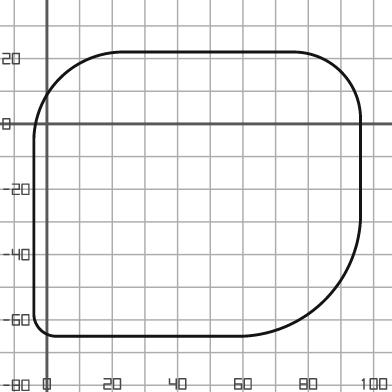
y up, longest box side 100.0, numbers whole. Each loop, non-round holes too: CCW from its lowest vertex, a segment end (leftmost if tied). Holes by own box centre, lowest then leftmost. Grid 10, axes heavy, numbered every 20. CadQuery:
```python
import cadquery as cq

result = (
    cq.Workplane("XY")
    .moveTo(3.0, -65.0)
    .lineTo(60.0, -65.0)
    .threePointArc((85.0, -54.0), (96.0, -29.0))
    .lineTo(96.0, 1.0)
    .threePointArc((90.0, 16.0), (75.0, 22.0))
    .lineTo(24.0, 22.0)
    .threePointArc((4.0, 14.0), (-4.0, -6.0))
    .lineTo(-4.0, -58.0)
    .threePointArc((-2.0, -63.0), (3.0, -65.0))
    .close()
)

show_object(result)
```